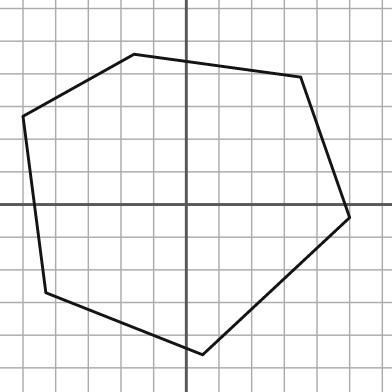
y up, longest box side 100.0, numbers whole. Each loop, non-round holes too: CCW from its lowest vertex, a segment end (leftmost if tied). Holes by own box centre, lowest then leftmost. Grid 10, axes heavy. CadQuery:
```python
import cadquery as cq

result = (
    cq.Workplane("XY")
    .moveTo(5.0, -46.0)
    .lineTo(50.0, -4.0)
    .lineTo(35.0, 39.0)
    .lineTo(-16.0, 46.0)
    .lineTo(-50.0, 27.0)
    .lineTo(-43.0, -27.0)
    .close()
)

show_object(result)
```